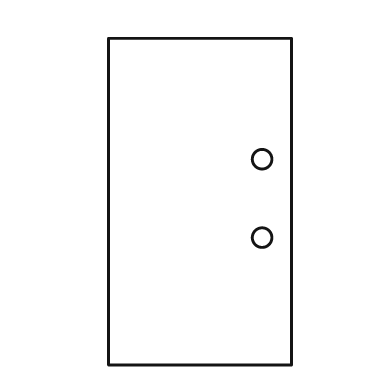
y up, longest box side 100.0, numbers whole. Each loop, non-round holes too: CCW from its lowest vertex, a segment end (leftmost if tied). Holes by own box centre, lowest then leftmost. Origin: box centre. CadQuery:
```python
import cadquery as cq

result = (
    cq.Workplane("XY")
    .moveTo(-28.0, -50.0)
    .lineTo(28.0, -50.0)
    .lineTo(28.0, 50.0)
    .lineTo(-28.0, 50.0)
    .close()
    .moveTo(19.0, -11.0)
    .circle(3.0)
    .moveTo(19.0, 13.0)
    .circle(3.0)
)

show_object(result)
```